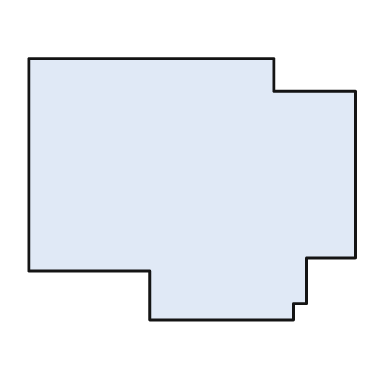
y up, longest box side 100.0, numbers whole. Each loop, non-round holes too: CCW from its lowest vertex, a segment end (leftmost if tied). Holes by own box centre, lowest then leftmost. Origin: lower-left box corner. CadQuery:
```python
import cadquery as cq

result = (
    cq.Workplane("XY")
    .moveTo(37.0, 0.0)
    .lineTo(81.0, 0.0)
    .lineTo(81.0, 5.0)
    .lineTo(85.0, 5.0)
    .lineTo(85.0, 19.0)
    .lineTo(100.0, 19.0)
    .lineTo(100.0, 70.0)
    .lineTo(75.0, 70.0)
    .lineTo(75.0, 80.0)
    .lineTo(0.0, 80.0)
    .lineTo(0.0, 15.0)
    .lineTo(37.0, 15.0)
    .close()
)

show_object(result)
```